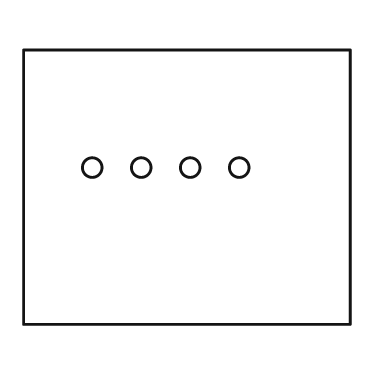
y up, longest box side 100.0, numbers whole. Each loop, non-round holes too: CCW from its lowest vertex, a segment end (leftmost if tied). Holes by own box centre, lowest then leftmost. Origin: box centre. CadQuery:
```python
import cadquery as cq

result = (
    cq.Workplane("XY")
    .moveTo(-50.0, -42.0)
    .lineTo(50.0, -42.0)
    .lineTo(50.0, 42.0)
    .lineTo(-50.0, 42.0)
    .close()
    .moveTo(-29.0, 6.0)
    .circle(3.0)
    .moveTo(-14.0, 6.0)
    .circle(3.0)
    .moveTo(1.0, 6.0)
    .circle(3.0)
    .moveTo(16.0, 6.0)
    .circle(3.0)
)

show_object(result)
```